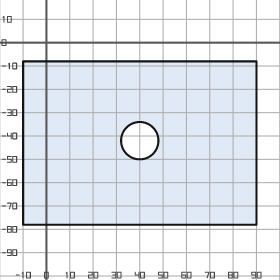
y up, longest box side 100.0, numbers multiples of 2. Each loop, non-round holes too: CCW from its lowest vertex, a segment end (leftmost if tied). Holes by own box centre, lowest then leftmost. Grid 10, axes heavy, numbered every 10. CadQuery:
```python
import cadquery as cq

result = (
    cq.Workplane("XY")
    .moveTo(-10.0, -78.0)
    .lineTo(90.0, -78.0)
    .lineTo(90.0, -8.0)
    .lineTo(-10.0, -8.0)
    .close()
    .moveTo(40.0, -42.0)
    .circle(8.0)
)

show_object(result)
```